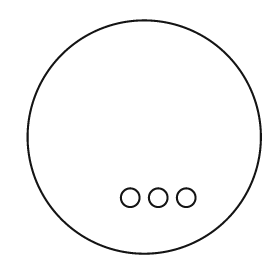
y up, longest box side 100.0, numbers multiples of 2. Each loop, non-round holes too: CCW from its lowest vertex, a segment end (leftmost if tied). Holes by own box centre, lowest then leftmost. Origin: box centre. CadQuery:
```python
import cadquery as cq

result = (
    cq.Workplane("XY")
    .moveTo(0.0, 0.0)
    .circle(50.0)
    .moveTo(-6.0, -26.0)
    .circle(4.0)
    .moveTo(6.0, -26.0)
    .circle(4.0)
    .moveTo(18.0, -26.0)
    .circle(4.0)
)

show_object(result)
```